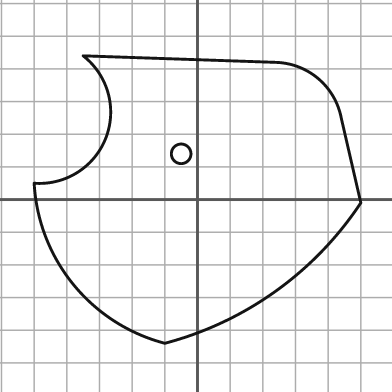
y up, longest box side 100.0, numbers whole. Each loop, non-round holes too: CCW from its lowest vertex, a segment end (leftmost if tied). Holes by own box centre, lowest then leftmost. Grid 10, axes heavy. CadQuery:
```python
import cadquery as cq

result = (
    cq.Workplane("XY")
    .moveTo(-10.0, -44.0)
    .threePointArc((24.0, -28.0), (50.0, -1.0))
    .lineTo(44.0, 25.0)
    .threePointArc((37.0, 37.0), (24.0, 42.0))
    .lineTo(-35.0, 44.0)
    .threePointArc((-28.0, 19.0), (-50.0, 5.0))
    .threePointArc((-38.0, -26.0), (-10.0, -44.0))
    .close()
    .moveTo(-5.0, 14.0)
    .circle(3.0)
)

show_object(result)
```